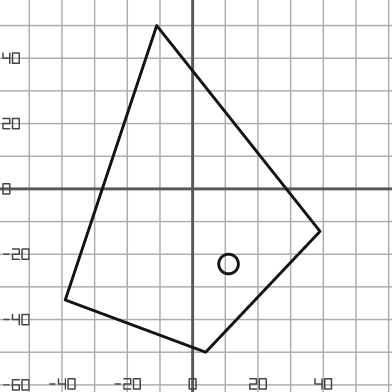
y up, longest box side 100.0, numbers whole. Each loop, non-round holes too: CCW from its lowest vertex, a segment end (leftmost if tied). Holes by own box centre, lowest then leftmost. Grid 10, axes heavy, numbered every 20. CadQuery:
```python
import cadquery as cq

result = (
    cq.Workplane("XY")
    .moveTo(4.0, -50.0)
    .lineTo(39.0, -13.0)
    .lineTo(-11.0, 50.0)
    .lineTo(-39.0, -34.0)
    .close()
    .moveTo(11.0, -23.0)
    .circle(3.0)
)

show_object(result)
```